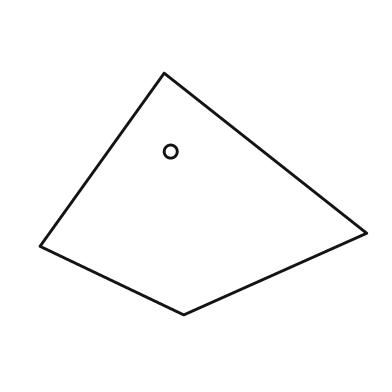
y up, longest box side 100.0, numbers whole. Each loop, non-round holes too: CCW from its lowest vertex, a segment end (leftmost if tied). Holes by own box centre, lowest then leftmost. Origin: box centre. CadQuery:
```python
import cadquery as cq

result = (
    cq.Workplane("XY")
    .moveTo(-6.0, -37.0)
    .lineTo(50.0, -12.0)
    .lineTo(-12.0, 37.0)
    .lineTo(-50.0, -16.0)
    .close()
    .moveTo(-10.0, 13.0)
    .circle(2.0)
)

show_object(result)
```